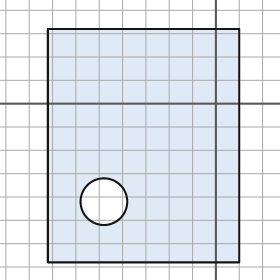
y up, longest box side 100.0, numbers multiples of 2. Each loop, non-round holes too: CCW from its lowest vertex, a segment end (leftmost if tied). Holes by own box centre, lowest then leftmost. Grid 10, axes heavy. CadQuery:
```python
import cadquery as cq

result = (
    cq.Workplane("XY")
    .moveTo(-72.0, -68.0)
    .lineTo(10.0, -68.0)
    .lineTo(10.0, 32.0)
    .lineTo(-72.0, 32.0)
    .close()
    .moveTo(-48.0, -42.0)
    .circle(10.0)
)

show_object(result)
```